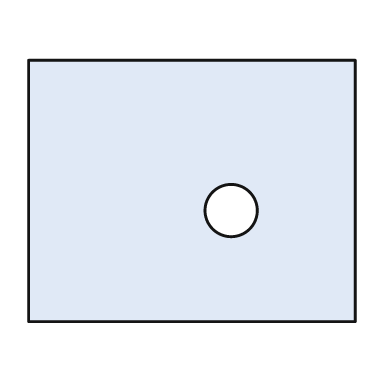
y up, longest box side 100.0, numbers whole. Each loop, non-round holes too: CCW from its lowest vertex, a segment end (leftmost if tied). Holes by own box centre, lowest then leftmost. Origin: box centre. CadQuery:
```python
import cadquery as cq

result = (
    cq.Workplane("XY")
    .moveTo(-50.0, -40.0)
    .lineTo(50.0, -40.0)
    .lineTo(50.0, 40.0)
    .lineTo(-50.0, 40.0)
    .close()
    .moveTo(12.0, -6.0)
    .circle(8.0)
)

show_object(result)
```